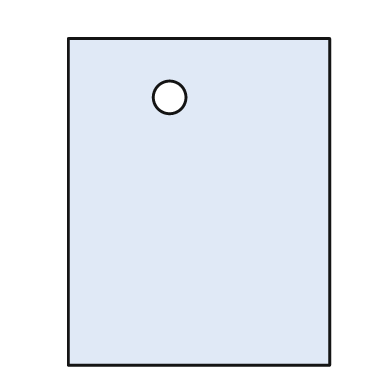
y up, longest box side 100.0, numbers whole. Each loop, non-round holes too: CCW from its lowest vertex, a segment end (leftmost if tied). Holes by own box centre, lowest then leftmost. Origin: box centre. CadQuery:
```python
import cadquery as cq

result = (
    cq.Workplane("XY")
    .moveTo(-40.0, -50.0)
    .lineTo(40.0, -50.0)
    .lineTo(40.0, 50.0)
    .lineTo(-40.0, 50.0)
    .close()
    .moveTo(-9.0, 32.0)
    .circle(5.0)
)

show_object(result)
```